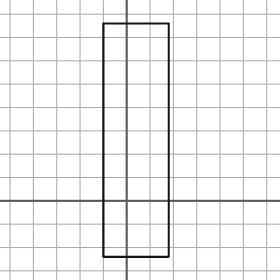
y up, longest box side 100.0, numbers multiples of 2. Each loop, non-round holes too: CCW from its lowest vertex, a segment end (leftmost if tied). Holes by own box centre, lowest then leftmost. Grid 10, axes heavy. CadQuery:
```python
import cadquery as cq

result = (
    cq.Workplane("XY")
    .moveTo(-10.0, -24.0)
    .lineTo(18.0, -24.0)
    .lineTo(18.0, 76.0)
    .lineTo(-10.0, 76.0)
    .close()
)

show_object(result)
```